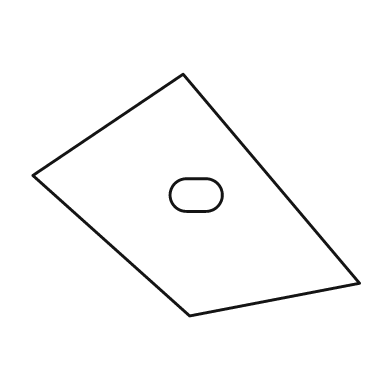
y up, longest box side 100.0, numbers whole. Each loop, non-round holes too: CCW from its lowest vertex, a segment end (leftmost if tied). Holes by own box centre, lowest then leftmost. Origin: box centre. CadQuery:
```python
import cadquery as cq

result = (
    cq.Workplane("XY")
    .moveTo(-2.0, -37.0)
    .lineTo(50.0, -27.0)
    .lineTo(-4.0, 37.0)
    .lineTo(-50.0, 6.0)
    .close()
    .moveTo(-3.0, -5.0)
    .lineTo(3.0, -5.0)
    .threePointArc((8.0, 0.0), (3.0, 5.0))
    .lineTo(-3.0, 5.0)
    .threePointArc((-8.0, 0.0), (-3.0, -5.0))
    .close()
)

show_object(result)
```